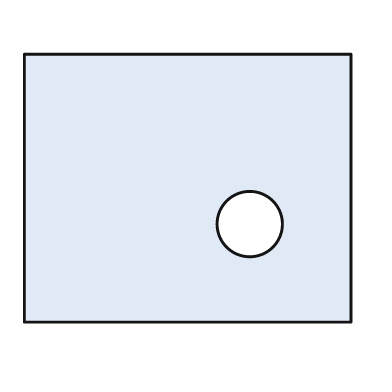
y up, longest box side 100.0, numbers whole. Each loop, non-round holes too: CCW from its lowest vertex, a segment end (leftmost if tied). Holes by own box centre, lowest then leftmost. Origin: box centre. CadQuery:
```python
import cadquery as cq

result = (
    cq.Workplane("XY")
    .moveTo(-50.0, -41.0)
    .lineTo(50.0, -41.0)
    .lineTo(50.0, 41.0)
    .lineTo(-50.0, 41.0)
    .close()
    .moveTo(19.0, -11.0)
    .circle(10.0)
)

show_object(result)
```